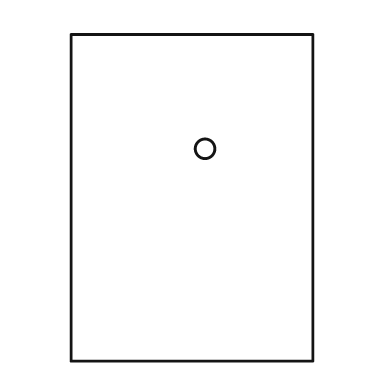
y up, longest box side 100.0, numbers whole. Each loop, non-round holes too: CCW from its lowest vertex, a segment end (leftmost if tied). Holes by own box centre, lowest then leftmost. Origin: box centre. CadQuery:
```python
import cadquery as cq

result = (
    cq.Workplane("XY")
    .moveTo(-37.0, -50.0)
    .lineTo(37.0, -50.0)
    .lineTo(37.0, 50.0)
    .lineTo(-37.0, 50.0)
    .close()
    .moveTo(4.0, 15.0)
    .circle(3.0)
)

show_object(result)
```